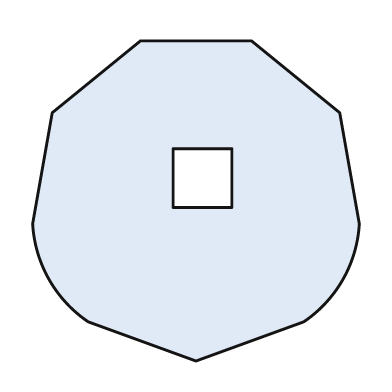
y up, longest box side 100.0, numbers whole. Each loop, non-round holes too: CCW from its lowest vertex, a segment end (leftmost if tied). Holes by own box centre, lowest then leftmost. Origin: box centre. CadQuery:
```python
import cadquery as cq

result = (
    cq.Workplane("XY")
    .moveTo(0.0, -49.0)
    .lineTo(33.0, -37.0)
    .threePointArc((45.0, -24.0), (50.0, -7.0))
    .lineTo(44.0, 27.0)
    .lineTo(17.0, 49.0)
    .lineTo(-17.0, 49.0)
    .lineTo(-44.0, 27.0)
    .lineTo(-50.0, -7.0)
    .threePointArc((-45.0, -24.0), (-33.0, -37.0))
    .close()
    .moveTo(-7.0, -2.0)
    .lineTo(11.0, -2.0)
    .lineTo(11.0, 16.0)
    .lineTo(-7.0, 16.0)
    .close()
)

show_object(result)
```